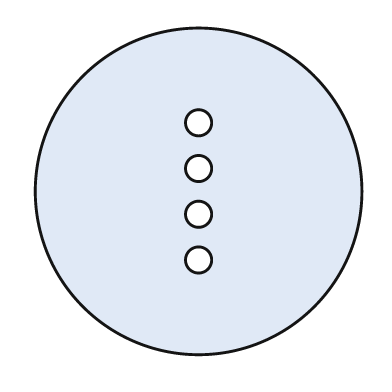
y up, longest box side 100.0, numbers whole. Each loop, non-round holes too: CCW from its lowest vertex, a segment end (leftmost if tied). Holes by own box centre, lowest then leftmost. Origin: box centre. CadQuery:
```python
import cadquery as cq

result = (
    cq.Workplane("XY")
    .moveTo(0.0, 0.0)
    .circle(50.0)
    .moveTo(0.0, -21.0)
    .circle(4.0)
    .moveTo(0.0, -7.0)
    .circle(4.0)
    .moveTo(0.0, 7.0)
    .circle(4.0)
    .moveTo(0.0, 21.0)
    .circle(4.0)
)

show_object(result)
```